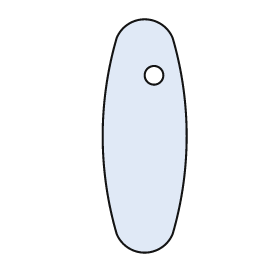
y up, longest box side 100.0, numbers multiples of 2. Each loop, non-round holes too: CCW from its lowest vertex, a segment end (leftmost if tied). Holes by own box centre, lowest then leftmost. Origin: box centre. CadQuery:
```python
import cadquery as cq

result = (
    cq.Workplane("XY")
    .moveTo(-12.0, -42.0)
    .threePointArc((0.0, -50.0), (12.0, -42.0))
    .threePointArc((18.0, 0.0), (12.0, 42.0))
    .threePointArc((0.0, 50.0), (-12.0, 42.0))
    .threePointArc((-18.0, 0.0), (-12.0, -42.0))
    .close()
    .moveTo(4.0, 26.0)
    .circle(4.0)
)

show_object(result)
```